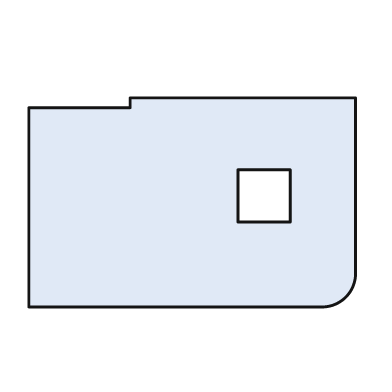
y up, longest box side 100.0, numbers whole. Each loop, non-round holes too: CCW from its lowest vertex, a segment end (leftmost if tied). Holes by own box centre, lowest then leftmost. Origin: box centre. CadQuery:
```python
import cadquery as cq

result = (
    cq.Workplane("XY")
    .moveTo(-50.0, -32.0)
    .lineTo(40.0, -32.0)
    .threePointArc((47.0, -29.0), (50.0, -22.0))
    .lineTo(50.0, 32.0)
    .lineTo(-19.0, 32.0)
    .lineTo(-19.0, 29.0)
    .lineTo(-50.0, 29.0)
    .close()
    .moveTo(14.0, -6.0)
    .lineTo(30.0, -6.0)
    .lineTo(30.0, 10.0)
    .lineTo(14.0, 10.0)
    .close()
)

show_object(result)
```